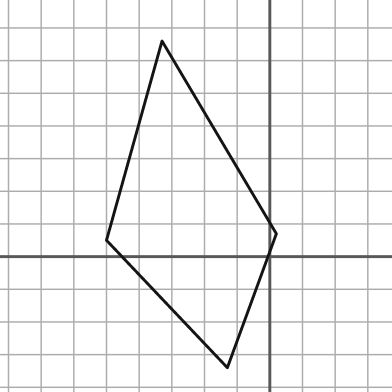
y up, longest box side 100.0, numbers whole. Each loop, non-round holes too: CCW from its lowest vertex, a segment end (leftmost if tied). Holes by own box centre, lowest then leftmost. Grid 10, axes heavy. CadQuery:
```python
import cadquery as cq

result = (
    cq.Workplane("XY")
    .moveTo(-13.0, -34.0)
    .lineTo(2.0, 7.0)
    .lineTo(-33.0, 66.0)
    .lineTo(-50.0, 5.0)
    .close()
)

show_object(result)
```